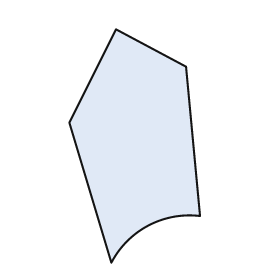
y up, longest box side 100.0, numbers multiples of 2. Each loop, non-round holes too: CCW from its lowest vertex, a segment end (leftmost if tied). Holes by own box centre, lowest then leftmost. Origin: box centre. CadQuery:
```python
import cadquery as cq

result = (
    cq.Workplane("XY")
    .moveTo(-10.0, -50.0)
    .threePointArc((6.0, -34.0), (28.0, -30.0))
    .lineTo(22.0, 34.0)
    .lineTo(-8.0, 50.0)
    .lineTo(-28.0, 10.0)
    .close()
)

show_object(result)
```